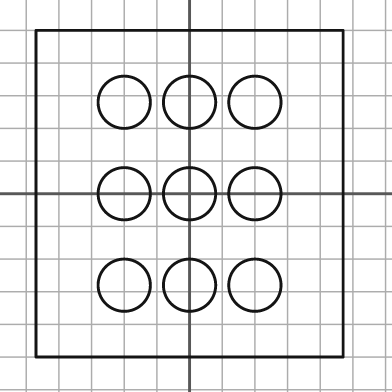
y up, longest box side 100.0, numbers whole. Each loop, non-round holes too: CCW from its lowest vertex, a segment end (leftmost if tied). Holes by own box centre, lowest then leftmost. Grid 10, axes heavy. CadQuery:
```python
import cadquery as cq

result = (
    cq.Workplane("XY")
    .moveTo(-47.0, -50.0)
    .lineTo(47.0, -50.0)
    .lineTo(47.0, 50.0)
    .lineTo(-47.0, 50.0)
    .close()
    .moveTo(-20.0, -28.0)
    .circle(8.0)
    .moveTo(0.0, -28.0)
    .circle(8.0)
    .moveTo(20.0, -28.0)
    .circle(8.0)
    .moveTo(-20.0, 0.0)
    .circle(8.0)
    .moveTo(0.0, 0.0)
    .circle(8.0)
    .moveTo(20.0, 0.0)
    .circle(8.0)
    .moveTo(-20.0, 28.0)
    .circle(8.0)
    .moveTo(0.0, 28.0)
    .circle(8.0)
    .moveTo(20.0, 28.0)
    .circle(8.0)
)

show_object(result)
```